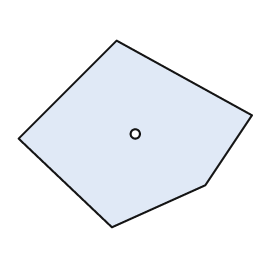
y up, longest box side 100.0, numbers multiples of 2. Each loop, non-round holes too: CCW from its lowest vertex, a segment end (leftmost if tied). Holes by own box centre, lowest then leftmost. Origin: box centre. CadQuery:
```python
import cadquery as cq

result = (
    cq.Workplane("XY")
    .moveTo(-10.0, -40.0)
    .lineTo(30.0, -22.0)
    .lineTo(50.0, 8.0)
    .lineTo(-8.0, 40.0)
    .lineTo(-50.0, -2.0)
    .close()
    .moveTo(0.0, 0.0)
    .circle(2.0)
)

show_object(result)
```